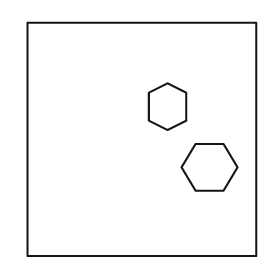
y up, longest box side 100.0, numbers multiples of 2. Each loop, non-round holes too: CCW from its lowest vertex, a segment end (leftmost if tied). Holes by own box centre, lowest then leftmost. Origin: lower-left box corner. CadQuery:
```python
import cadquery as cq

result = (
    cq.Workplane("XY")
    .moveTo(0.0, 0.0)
    .lineTo(98.0, 0.0)
    .lineTo(98.0, 100.0)
    .lineTo(0.0, 100.0)
    .close()
    .moveTo(72.0, 28.0)
    .lineTo(84.0, 28.0)
    .lineTo(90.0, 38.0)
    .lineTo(84.0, 48.0)
    .lineTo(72.0, 48.0)
    .lineTo(66.0, 38.0)
    .close()
    .moveTo(60.0, 54.0)
    .lineTo(68.0, 58.0)
    .lineTo(68.0, 70.0)
    .lineTo(60.0, 74.0)
    .lineTo(52.0, 70.0)
    .lineTo(52.0, 58.0)
    .close()
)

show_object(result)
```